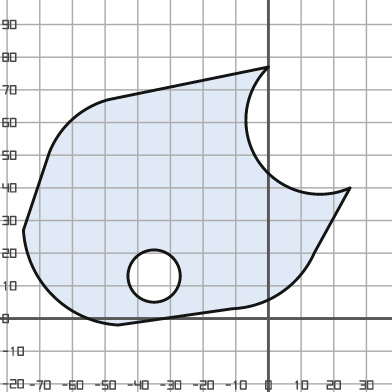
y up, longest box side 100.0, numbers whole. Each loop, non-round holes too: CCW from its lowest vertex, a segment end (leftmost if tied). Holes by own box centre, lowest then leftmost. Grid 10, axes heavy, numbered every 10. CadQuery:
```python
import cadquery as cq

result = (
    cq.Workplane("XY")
    .moveTo(-46.0, -2.0)
    .lineTo(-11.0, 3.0)
    .threePointArc((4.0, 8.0), (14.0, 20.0))
    .lineTo(25.0, 40.0)
    .threePointArc((-3.0, 48.0), (0.0, 77.0))
    .lineTo(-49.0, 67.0)
    .threePointArc((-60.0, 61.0), (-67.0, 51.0))
    .lineTo(-75.0, 27.0)
    .threePointArc((-66.0, 7.0), (-46.0, -2.0))
    .close()
    .moveTo(-35.0, 13.0)
    .circle(8.0)
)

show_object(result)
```